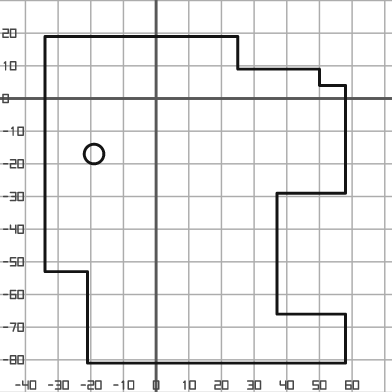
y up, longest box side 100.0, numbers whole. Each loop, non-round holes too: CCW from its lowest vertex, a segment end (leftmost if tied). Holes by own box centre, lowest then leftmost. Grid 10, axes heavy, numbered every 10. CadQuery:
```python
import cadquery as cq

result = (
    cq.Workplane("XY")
    .moveTo(-21.0, -81.0)
    .lineTo(58.0, -81.0)
    .lineTo(58.0, -66.0)
    .lineTo(37.0, -66.0)
    .lineTo(37.0, -29.0)
    .lineTo(58.0, -29.0)
    .lineTo(58.0, 4.0)
    .lineTo(50.0, 4.0)
    .lineTo(50.0, 9.0)
    .lineTo(25.0, 9.0)
    .lineTo(25.0, 19.0)
    .lineTo(-34.0, 19.0)
    .lineTo(-34.0, -53.0)
    .lineTo(-21.0, -53.0)
    .close()
    .moveTo(-19.0, -17.0)
    .circle(3.0)
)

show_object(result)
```